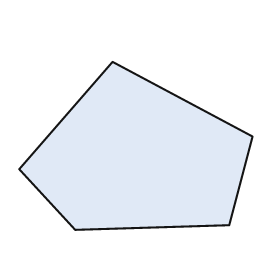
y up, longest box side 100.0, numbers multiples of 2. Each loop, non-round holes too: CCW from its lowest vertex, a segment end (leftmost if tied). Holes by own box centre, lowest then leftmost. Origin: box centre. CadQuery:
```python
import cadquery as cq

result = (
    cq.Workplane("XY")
    .moveTo(-26.0, -36.0)
    .lineTo(40.0, -34.0)
    .lineTo(50.0, 4.0)
    .lineTo(-10.0, 36.0)
    .lineTo(-50.0, -10.0)
    .close()
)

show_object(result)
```